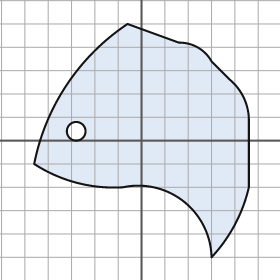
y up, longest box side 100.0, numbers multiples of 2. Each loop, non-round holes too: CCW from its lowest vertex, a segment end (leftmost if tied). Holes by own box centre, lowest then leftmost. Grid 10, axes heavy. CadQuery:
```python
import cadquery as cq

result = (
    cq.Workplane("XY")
    .moveTo(30.0, -50.0)
    .threePointArc((40.0, -36.0), (46.0, -20.0))
    .lineTo(46.0, 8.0)
    .threePointArc((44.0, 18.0), (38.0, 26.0))
    .lineTo(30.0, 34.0)
    .threePointArc((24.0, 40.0), (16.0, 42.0))
    .lineTo(-6.0, 50.0)
    .threePointArc((-32.0, 24.0), (-46.0, -10.0))
    .threePointArc((-28.0, -18.0), (-8.0, -20.0))
    .threePointArc((18.0, -26.0), (30.0, -50.0))
    .close()
    .moveTo(-28.0, 4.0)
    .circle(4.0)
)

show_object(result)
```